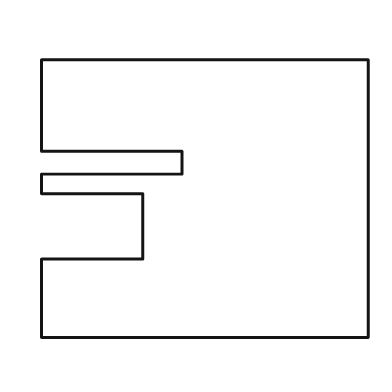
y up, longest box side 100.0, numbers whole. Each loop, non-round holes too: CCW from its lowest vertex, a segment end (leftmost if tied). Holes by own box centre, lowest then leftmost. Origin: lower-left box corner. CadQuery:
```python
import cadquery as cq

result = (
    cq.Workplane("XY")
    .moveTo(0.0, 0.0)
    .lineTo(100.0, 0.0)
    .lineTo(100.0, 85.0)
    .lineTo(0.0, 85.0)
    .lineTo(0.0, 57.0)
    .lineTo(43.0, 57.0)
    .lineTo(43.0, 50.0)
    .lineTo(0.0, 50.0)
    .lineTo(0.0, 44.0)
    .lineTo(31.0, 44.0)
    .lineTo(31.0, 24.0)
    .lineTo(0.0, 24.0)
    .close()
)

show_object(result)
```